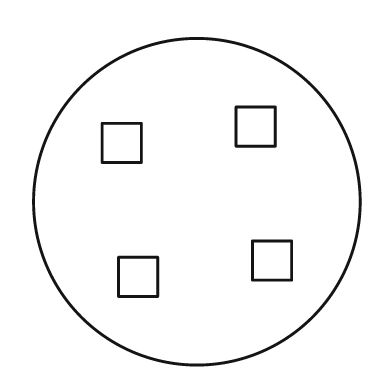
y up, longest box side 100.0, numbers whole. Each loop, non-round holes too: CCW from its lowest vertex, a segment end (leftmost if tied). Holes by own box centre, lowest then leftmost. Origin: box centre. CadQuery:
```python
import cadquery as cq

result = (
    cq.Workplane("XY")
    .moveTo(0.0, 0.0)
    .circle(50.0)
    .moveTo(-24.0, -29.0)
    .lineTo(-12.0, -29.0)
    .lineTo(-12.0, -17.0)
    .lineTo(-24.0, -17.0)
    .close()
    .moveTo(17.0, -24.0)
    .lineTo(29.0, -24.0)
    .lineTo(29.0, -12.0)
    .lineTo(17.0, -12.0)
    .close()
    .moveTo(-29.0, 12.0)
    .lineTo(-17.0, 12.0)
    .lineTo(-17.0, 24.0)
    .lineTo(-29.0, 24.0)
    .close()
    .moveTo(12.0, 17.0)
    .lineTo(24.0, 17.0)
    .lineTo(24.0, 29.0)
    .lineTo(12.0, 29.0)
    .close()
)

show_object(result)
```